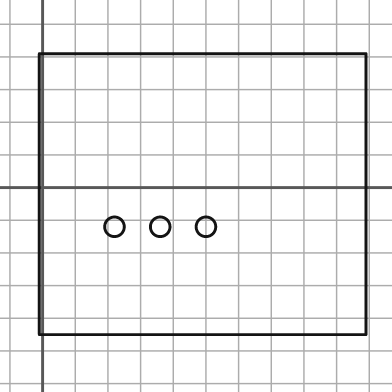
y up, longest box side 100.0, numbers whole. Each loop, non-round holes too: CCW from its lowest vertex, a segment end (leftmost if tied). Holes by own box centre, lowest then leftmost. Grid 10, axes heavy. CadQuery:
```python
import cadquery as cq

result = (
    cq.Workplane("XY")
    .moveTo(-1.0, -45.0)
    .lineTo(99.0, -45.0)
    .lineTo(99.0, 41.0)
    .lineTo(-1.0, 41.0)
    .close()
    .moveTo(22.0, -12.0)
    .circle(3.0)
    .moveTo(36.0, -12.0)
    .circle(3.0)
    .moveTo(50.0, -12.0)
    .circle(3.0)
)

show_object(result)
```